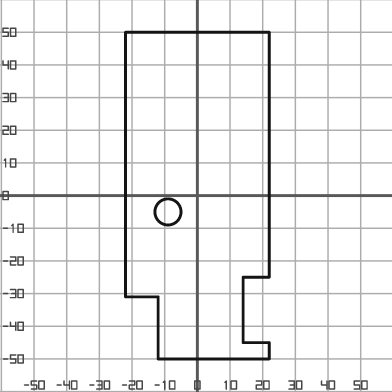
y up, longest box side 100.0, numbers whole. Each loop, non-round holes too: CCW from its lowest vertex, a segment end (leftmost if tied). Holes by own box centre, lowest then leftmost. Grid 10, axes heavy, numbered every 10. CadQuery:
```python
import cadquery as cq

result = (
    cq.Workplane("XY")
    .moveTo(-12.0, -50.0)
    .lineTo(22.0, -50.0)
    .lineTo(22.0, -45.0)
    .lineTo(14.0, -45.0)
    .lineTo(14.0, -25.0)
    .lineTo(22.0, -25.0)
    .lineTo(22.0, 50.0)
    .lineTo(-22.0, 50.0)
    .lineTo(-22.0, -31.0)
    .lineTo(-12.0, -31.0)
    .close()
    .moveTo(-9.0, -5.0)
    .circle(4.0)
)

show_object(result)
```